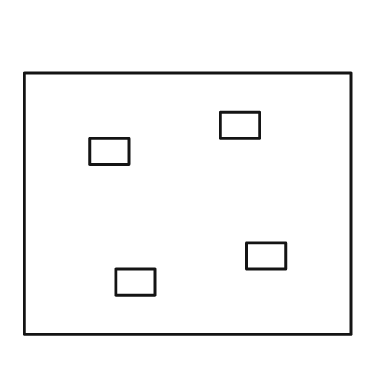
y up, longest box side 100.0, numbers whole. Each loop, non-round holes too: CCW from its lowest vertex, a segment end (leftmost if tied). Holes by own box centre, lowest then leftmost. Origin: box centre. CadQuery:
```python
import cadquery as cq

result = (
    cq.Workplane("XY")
    .moveTo(-50.0, -40.0)
    .lineTo(50.0, -40.0)
    .lineTo(50.0, 40.0)
    .lineTo(-50.0, 40.0)
    .close()
    .moveTo(-22.0, -28.0)
    .lineTo(-10.0, -28.0)
    .lineTo(-10.0, -20.0)
    .lineTo(-22.0, -20.0)
    .close()
    .moveTo(18.0, -20.0)
    .lineTo(30.0, -20.0)
    .lineTo(30.0, -12.0)
    .lineTo(18.0, -12.0)
    .close()
    .moveTo(-30.0, 12.0)
    .lineTo(-18.0, 12.0)
    .lineTo(-18.0, 20.0)
    .lineTo(-30.0, 20.0)
    .close()
    .moveTo(10.0, 20.0)
    .lineTo(22.0, 20.0)
    .lineTo(22.0, 28.0)
    .lineTo(10.0, 28.0)
    .close()
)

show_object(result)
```